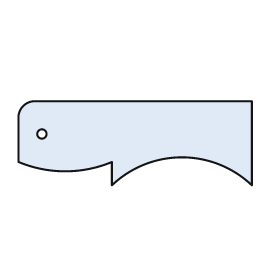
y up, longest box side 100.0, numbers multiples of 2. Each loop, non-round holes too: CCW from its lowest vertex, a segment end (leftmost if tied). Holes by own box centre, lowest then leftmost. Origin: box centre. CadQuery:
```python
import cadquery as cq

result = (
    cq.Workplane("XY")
    .moveTo(-10.0, -18.0)
    .threePointArc((20.0, -6.0), (50.0, -18.0))
    .lineTo(50.0, 18.0)
    .lineTo(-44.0, 18.0)
    .threePointArc((-48.0, 16.0), (-50.0, 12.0))
    .lineTo(-50.0, -8.0)
    .threePointArc((-30.0, -12.0), (-10.0, -8.0))
    .close()
    .moveTo(-40.0, 4.0)
    .circle(2.0)
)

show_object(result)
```